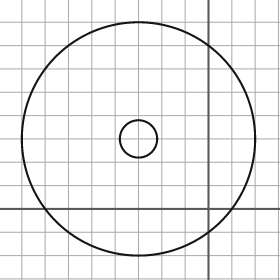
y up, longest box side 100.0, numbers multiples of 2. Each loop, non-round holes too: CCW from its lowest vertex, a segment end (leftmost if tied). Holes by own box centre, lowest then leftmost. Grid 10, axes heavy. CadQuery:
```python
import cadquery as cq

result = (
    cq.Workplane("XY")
    .moveTo(-30.0, 30.0)
    .circle(50.0)
    .moveTo(-30.0, 30.0)
    .circle(8.0)
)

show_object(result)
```